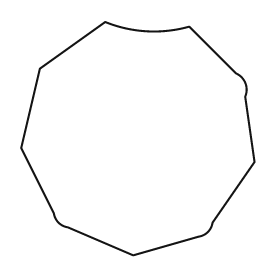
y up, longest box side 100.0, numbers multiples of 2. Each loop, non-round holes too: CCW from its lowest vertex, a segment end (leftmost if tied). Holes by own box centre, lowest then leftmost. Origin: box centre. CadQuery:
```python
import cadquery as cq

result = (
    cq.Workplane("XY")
    .moveTo(-2.0, -50.0)
    .lineTo(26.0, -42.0)
    .threePointArc((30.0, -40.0), (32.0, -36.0))
    .lineTo(50.0, -10.0)
    .lineTo(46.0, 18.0)
    .threePointArc((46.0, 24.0), (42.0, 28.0))
    .lineTo(22.0, 48.0)
    .threePointArc((4.0, 46.0), (-14.0, 50.0))
    .lineTo(-42.0, 30.0)
    .lineTo(-50.0, -4.0)
    .lineTo(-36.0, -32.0)
    .threePointArc((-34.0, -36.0), (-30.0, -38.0))
    .close()
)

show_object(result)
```